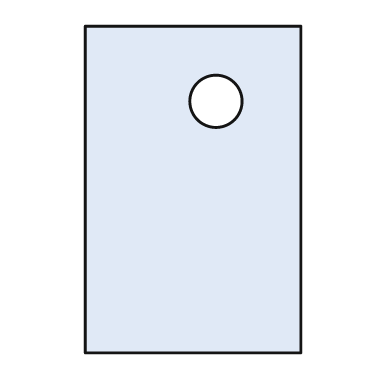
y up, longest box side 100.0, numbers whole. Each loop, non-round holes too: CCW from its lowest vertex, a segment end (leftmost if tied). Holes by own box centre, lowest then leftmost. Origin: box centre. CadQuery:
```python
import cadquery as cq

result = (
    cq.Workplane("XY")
    .moveTo(-33.0, -50.0)
    .lineTo(33.0, -50.0)
    .lineTo(33.0, 50.0)
    .lineTo(-33.0, 50.0)
    .close()
    .moveTo(7.0, 27.0)
    .circle(8.0)
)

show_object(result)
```